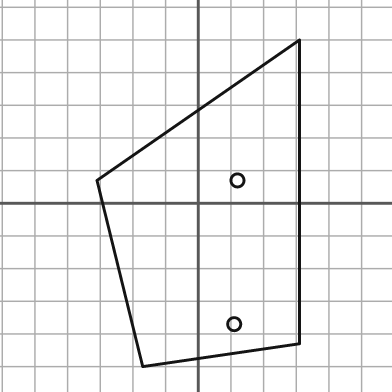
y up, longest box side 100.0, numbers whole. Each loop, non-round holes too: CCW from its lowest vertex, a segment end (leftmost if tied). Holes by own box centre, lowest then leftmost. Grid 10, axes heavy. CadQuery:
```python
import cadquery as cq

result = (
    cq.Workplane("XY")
    .moveTo(-17.0, -50.0)
    .lineTo(31.0, -43.0)
    .lineTo(31.0, 50.0)
    .lineTo(-31.0, 7.0)
    .close()
    .moveTo(11.0, -37.0)
    .circle(2.0)
    .moveTo(12.0, 7.0)
    .circle(2.0)
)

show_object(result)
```